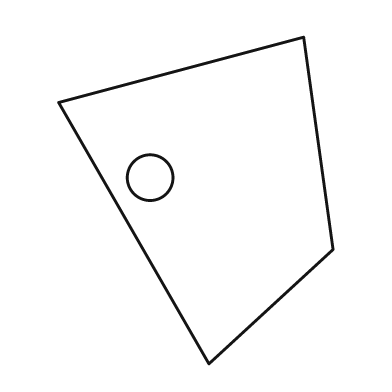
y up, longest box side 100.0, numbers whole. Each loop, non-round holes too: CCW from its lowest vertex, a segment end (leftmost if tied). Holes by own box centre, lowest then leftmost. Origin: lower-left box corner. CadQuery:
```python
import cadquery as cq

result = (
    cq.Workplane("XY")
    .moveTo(46.0, 0.0)
    .lineTo(84.0, 35.0)
    .lineTo(75.0, 100.0)
    .lineTo(0.0, 80.0)
    .close()
    .moveTo(28.0, 57.0)
    .circle(7.0)
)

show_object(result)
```